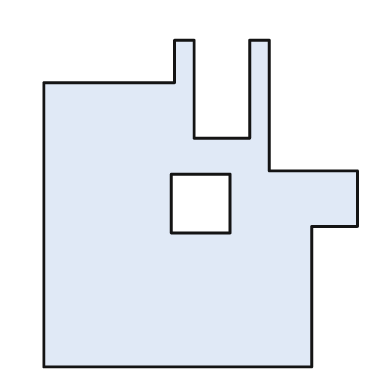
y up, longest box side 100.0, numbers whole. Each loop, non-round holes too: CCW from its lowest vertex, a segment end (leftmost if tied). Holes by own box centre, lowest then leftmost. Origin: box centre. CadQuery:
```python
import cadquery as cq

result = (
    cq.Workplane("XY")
    .moveTo(-48.0, -50.0)
    .lineTo(34.0, -50.0)
    .lineTo(34.0, -7.0)
    .lineTo(48.0, -7.0)
    .lineTo(48.0, 10.0)
    .lineTo(21.0, 10.0)
    .lineTo(21.0, 50.0)
    .lineTo(15.0, 50.0)
    .lineTo(15.0, 20.0)
    .lineTo(-2.0, 20.0)
    .lineTo(-2.0, 50.0)
    .lineTo(-8.0, 50.0)
    .lineTo(-8.0, 37.0)
    .lineTo(-48.0, 37.0)
    .close()
    .moveTo(-9.0, -9.0)
    .lineTo(9.0, -9.0)
    .lineTo(9.0, 9.0)
    .lineTo(-9.0, 9.0)
    .close()
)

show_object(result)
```